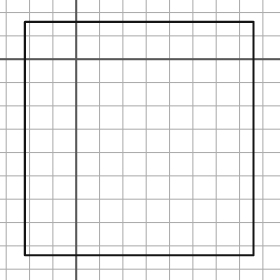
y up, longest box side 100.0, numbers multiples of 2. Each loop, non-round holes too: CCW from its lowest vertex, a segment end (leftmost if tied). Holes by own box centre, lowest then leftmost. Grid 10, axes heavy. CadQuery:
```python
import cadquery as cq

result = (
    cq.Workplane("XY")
    .moveTo(-22.0, -84.0)
    .lineTo(76.0, -84.0)
    .lineTo(76.0, 16.0)
    .lineTo(-22.0, 16.0)
    .close()
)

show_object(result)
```